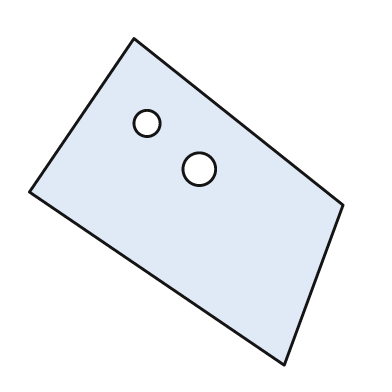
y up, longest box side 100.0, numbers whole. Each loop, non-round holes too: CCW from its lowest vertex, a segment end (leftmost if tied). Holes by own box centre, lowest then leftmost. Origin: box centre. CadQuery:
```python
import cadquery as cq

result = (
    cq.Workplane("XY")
    .moveTo(30.0, -50.0)
    .lineTo(48.0, -1.0)
    .lineTo(-16.0, 50.0)
    .lineTo(-48.0, 3.0)
    .close()
    .moveTo(4.0, 10.0)
    .circle(5.0)
    .moveTo(-12.0, 24.0)
    .circle(4.0)
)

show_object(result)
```